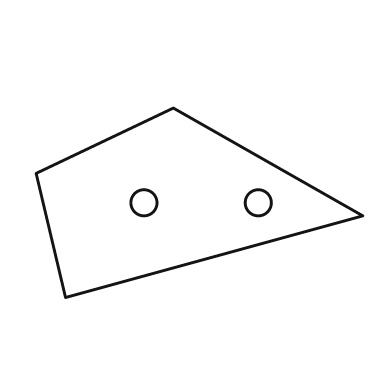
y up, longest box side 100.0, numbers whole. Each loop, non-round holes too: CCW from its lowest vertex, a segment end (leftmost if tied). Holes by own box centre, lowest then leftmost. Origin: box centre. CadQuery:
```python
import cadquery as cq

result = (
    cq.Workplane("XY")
    .moveTo(-41.0, -29.0)
    .lineTo(50.0, -4.0)
    .lineTo(-8.0, 29.0)
    .lineTo(-50.0, 9.0)
    .close()
    .moveTo(-17.0, 0.0)
    .circle(4.0)
    .moveTo(18.0, 0.0)
    .circle(4.0)
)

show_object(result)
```